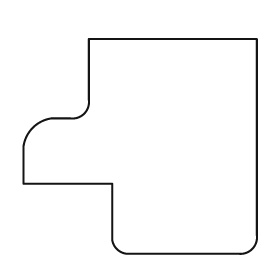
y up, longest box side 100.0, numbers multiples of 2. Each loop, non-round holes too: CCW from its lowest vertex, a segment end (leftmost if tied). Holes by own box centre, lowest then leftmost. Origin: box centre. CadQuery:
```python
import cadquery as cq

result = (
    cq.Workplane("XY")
    .moveTo(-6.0, -46.0)
    .lineTo(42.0, -46.0)
    .threePointArc((48.0, -44.0), (50.0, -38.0))
    .lineTo(50.0, 46.0)
    .lineTo(-22.0, 46.0)
    .lineTo(-22.0, 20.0)
    .threePointArc((-24.0, 14.0), (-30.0, 12.0))
    .lineTo(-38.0, 12.0)
    .threePointArc((-46.0, 8.0), (-50.0, 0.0))
    .lineTo(-50.0, -16.0)
    .lineTo(-12.0, -16.0)
    .lineTo(-12.0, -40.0)
    .threePointArc((-10.0, -44.0), (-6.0, -46.0))
    .close()
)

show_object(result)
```